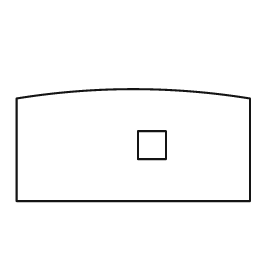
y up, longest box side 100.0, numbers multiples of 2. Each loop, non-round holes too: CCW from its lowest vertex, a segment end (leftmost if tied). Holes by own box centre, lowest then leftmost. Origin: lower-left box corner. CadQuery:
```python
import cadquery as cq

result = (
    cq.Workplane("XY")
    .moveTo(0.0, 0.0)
    .lineTo(100.0, 0.0)
    .lineTo(100.0, 44.0)
    .threePointArc((50.0, 48.0), (0.0, 44.0))
    .close()
    .moveTo(52.0, 18.0)
    .lineTo(64.0, 18.0)
    .lineTo(64.0, 30.0)
    .lineTo(52.0, 30.0)
    .close()
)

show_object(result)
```